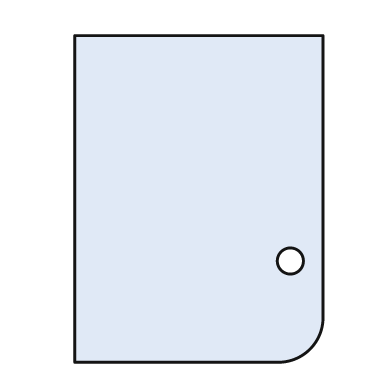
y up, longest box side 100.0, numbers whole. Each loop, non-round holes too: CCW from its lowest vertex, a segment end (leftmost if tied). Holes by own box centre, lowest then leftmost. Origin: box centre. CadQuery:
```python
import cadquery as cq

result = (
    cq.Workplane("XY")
    .moveTo(-38.0, -50.0)
    .lineTo(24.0, -50.0)
    .threePointArc((34.0, -46.0), (38.0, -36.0))
    .lineTo(38.0, 50.0)
    .lineTo(-38.0, 50.0)
    .close()
    .moveTo(28.0, -19.0)
    .circle(4.0)
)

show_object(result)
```